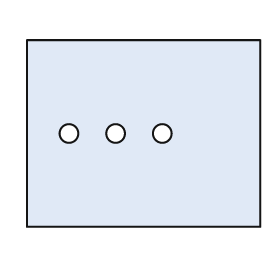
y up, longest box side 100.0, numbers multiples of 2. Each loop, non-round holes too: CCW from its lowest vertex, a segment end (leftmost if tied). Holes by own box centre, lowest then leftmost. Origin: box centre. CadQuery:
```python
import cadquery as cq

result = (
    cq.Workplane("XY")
    .moveTo(-50.0, -40.0)
    .lineTo(50.0, -40.0)
    .lineTo(50.0, 40.0)
    .lineTo(-50.0, 40.0)
    .close()
    .moveTo(-32.0, 0.0)
    .circle(4.0)
    .moveTo(-12.0, 0.0)
    .circle(4.0)
    .moveTo(8.0, 0.0)
    .circle(4.0)
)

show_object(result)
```